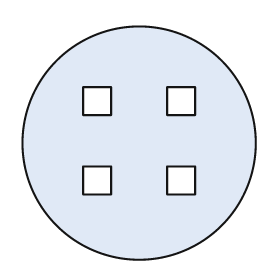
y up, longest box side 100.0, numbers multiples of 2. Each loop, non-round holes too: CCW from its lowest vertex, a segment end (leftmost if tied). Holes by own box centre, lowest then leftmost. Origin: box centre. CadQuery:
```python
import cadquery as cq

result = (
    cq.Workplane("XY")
    .moveTo(0.0, 0.0)
    .circle(50.0)
    .moveTo(-24.0, -22.0)
    .lineTo(-12.0, -22.0)
    .lineTo(-12.0, -10.0)
    .lineTo(-24.0, -10.0)
    .close()
    .moveTo(12.0, -22.0)
    .lineTo(24.0, -22.0)
    .lineTo(24.0, -10.0)
    .lineTo(12.0, -10.0)
    .close()
    .moveTo(-24.0, 12.0)
    .lineTo(-12.0, 12.0)
    .lineTo(-12.0, 24.0)
    .lineTo(-24.0, 24.0)
    .close()
    .moveTo(12.0, 12.0)
    .lineTo(24.0, 12.0)
    .lineTo(24.0, 24.0)
    .lineTo(12.0, 24.0)
    .close()
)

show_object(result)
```